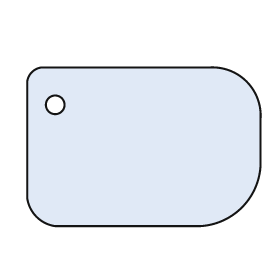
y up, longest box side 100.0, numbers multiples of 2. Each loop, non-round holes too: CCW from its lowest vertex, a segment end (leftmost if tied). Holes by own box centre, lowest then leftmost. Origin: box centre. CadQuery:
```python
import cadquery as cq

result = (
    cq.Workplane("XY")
    .moveTo(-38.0, -34.0)
    .lineTo(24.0, -34.0)
    .threePointArc((42.0, -26.0), (50.0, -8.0))
    .lineTo(50.0, 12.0)
    .threePointArc((44.0, 28.0), (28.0, 34.0))
    .lineTo(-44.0, 34.0)
    .threePointArc((-48.0, 32.0), (-50.0, 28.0))
    .lineTo(-50.0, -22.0)
    .threePointArc((-46.0, -30.0), (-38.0, -34.0))
    .close()
    .moveTo(-38.0, 18.0)
    .circle(4.0)
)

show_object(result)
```